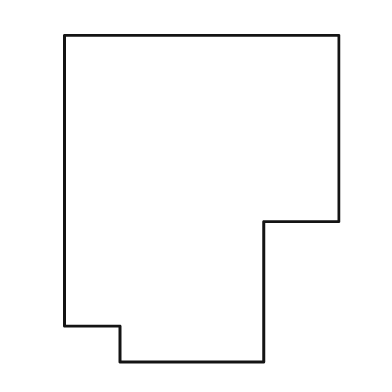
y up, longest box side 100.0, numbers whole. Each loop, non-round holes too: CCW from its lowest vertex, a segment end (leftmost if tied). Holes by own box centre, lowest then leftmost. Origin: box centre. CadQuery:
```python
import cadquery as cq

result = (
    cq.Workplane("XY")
    .moveTo(-25.0, -50.0)
    .lineTo(19.0, -50.0)
    .lineTo(19.0, -7.0)
    .lineTo(42.0, -7.0)
    .lineTo(42.0, 50.0)
    .lineTo(-42.0, 50.0)
    .lineTo(-42.0, -39.0)
    .lineTo(-25.0, -39.0)
    .close()
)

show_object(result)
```